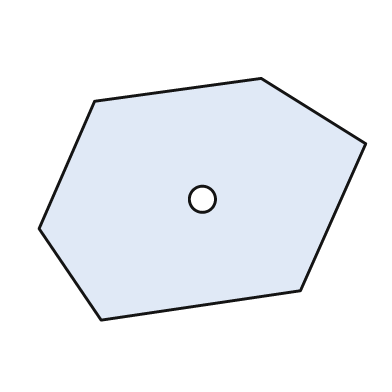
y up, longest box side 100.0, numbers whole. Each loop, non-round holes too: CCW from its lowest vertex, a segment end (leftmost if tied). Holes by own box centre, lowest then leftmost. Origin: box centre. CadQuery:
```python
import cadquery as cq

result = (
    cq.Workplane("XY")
    .moveTo(-31.0, -37.0)
    .lineTo(30.0, -28.0)
    .lineTo(50.0, 17.0)
    .lineTo(18.0, 37.0)
    .lineTo(-33.0, 30.0)
    .lineTo(-50.0, -9.0)
    .close()
    .moveTo(0.0, 0.0)
    .circle(4.0)
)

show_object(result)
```